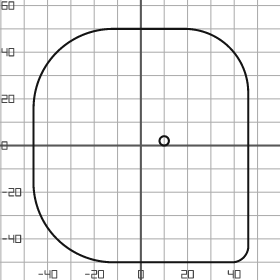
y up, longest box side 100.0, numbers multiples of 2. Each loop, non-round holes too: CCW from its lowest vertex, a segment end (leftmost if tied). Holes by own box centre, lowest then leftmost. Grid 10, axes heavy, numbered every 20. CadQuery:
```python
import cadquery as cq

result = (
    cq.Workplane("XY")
    .moveTo(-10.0, -50.0)
    .lineTo(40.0, -50.0)
    .threePointArc((44.0, -48.0), (46.0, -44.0))
    .lineTo(46.0, 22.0)
    .threePointArc((38.0, 42.0), (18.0, 50.0))
    .lineTo(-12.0, 50.0)
    .threePointArc((-36.0, 40.0), (-46.0, 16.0))
    .lineTo(-46.0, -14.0)
    .threePointArc((-36.0, -40.0), (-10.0, -50.0))
    .close()
    .moveTo(10.0, 2.0)
    .circle(2.0)
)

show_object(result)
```